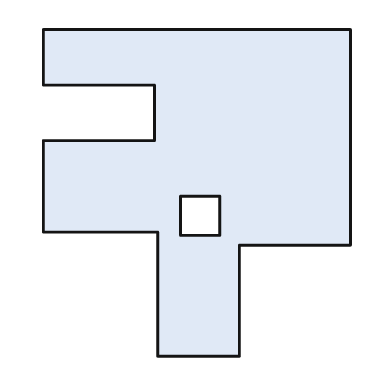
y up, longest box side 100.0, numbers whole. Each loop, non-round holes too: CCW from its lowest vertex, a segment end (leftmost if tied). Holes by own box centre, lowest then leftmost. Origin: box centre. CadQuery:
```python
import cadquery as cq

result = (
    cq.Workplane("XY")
    .moveTo(-12.0, -50.0)
    .lineTo(13.0, -50.0)
    .lineTo(13.0, -16.0)
    .lineTo(47.0, -16.0)
    .lineTo(47.0, 50.0)
    .lineTo(-47.0, 50.0)
    .lineTo(-47.0, 33.0)
    .lineTo(-13.0, 33.0)
    .lineTo(-13.0, 16.0)
    .lineTo(-47.0, 16.0)
    .lineTo(-47.0, -12.0)
    .lineTo(-12.0, -12.0)
    .close()
    .moveTo(-5.0, -13.0)
    .lineTo(7.0, -13.0)
    .lineTo(7.0, -1.0)
    .lineTo(-5.0, -1.0)
    .close()
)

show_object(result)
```